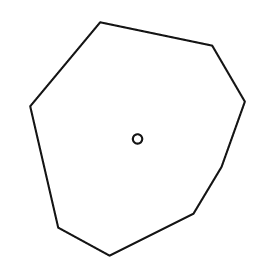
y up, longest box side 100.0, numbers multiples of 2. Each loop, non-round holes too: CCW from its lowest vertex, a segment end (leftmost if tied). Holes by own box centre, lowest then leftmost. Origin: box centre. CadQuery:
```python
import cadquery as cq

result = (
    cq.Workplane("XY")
    .moveTo(-12.0, -50.0)
    .lineTo(24.0, -32.0)
    .lineTo(36.0, -12.0)
    .lineTo(46.0, 16.0)
    .lineTo(32.0, 40.0)
    .lineTo(-16.0, 50.0)
    .lineTo(-46.0, 14.0)
    .lineTo(-34.0, -38.0)
    .close()
    .moveTo(0.0, 0.0)
    .circle(2.0)
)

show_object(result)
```